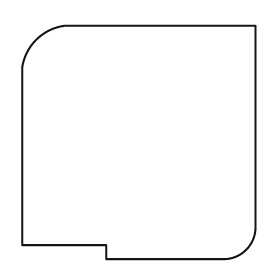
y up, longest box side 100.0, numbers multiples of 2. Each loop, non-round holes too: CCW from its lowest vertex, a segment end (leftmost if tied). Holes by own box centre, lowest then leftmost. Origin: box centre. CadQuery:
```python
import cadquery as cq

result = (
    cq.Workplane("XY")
    .moveTo(-14.0, -50.0)
    .lineTo(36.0, -50.0)
    .threePointArc((46.0, -46.0), (50.0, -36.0))
    .lineTo(50.0, 50.0)
    .lineTo(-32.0, 50.0)
    .threePointArc((-44.0, 44.0), (-50.0, 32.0))
    .lineTo(-50.0, -44.0)
    .lineTo(-14.0, -44.0)
    .close()
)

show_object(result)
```